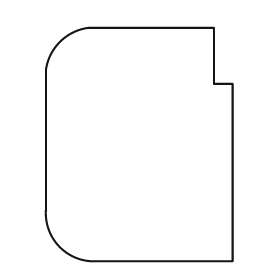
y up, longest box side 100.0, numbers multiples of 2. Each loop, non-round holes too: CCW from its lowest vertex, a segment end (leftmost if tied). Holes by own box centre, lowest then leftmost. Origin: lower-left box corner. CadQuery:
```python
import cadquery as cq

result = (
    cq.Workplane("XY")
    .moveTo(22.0, 0.0)
    .lineTo(80.0, 0.0)
    .lineTo(80.0, 76.0)
    .lineTo(72.0, 76.0)
    .lineTo(72.0, 100.0)
    .lineTo(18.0, 100.0)
    .threePointArc((6.0, 94.0), (0.0, 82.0))
    .lineTo(0.0, 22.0)
    .threePointArc((6.0, 6.0), (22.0, 0.0))
    .close()
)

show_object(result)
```